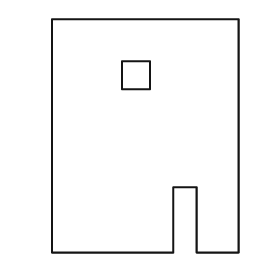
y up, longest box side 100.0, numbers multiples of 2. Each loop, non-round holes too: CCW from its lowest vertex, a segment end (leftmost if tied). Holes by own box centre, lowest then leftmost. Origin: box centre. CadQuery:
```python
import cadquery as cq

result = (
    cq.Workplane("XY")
    .moveTo(-40.0, -50.0)
    .lineTo(12.0, -50.0)
    .lineTo(12.0, -22.0)
    .lineTo(22.0, -22.0)
    .lineTo(22.0, -50.0)
    .lineTo(40.0, -50.0)
    .lineTo(40.0, 50.0)
    .lineTo(-40.0, 50.0)
    .close()
    .moveTo(-10.0, 20.0)
    .lineTo(2.0, 20.0)
    .lineTo(2.0, 32.0)
    .lineTo(-10.0, 32.0)
    .close()
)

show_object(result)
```